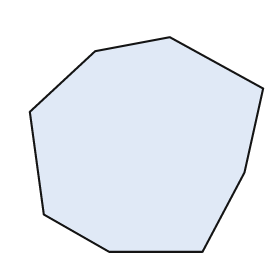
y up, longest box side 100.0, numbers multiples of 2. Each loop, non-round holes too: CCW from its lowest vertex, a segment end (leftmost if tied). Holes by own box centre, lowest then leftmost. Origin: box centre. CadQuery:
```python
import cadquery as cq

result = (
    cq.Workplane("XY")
    .moveTo(-16.0, -46.0)
    .lineTo(24.0, -46.0)
    .lineTo(42.0, -12.0)
    .lineTo(50.0, 24.0)
    .lineTo(10.0, 46.0)
    .lineTo(-22.0, 40.0)
    .lineTo(-50.0, 14.0)
    .lineTo(-44.0, -30.0)
    .close()
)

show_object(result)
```